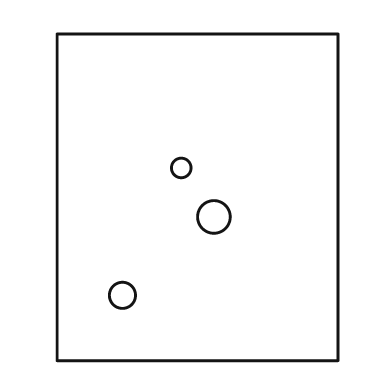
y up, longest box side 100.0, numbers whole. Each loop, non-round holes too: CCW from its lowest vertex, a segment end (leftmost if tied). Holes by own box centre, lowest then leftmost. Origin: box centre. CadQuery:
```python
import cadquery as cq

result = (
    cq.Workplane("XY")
    .moveTo(-43.0, -50.0)
    .lineTo(43.0, -50.0)
    .lineTo(43.0, 50.0)
    .lineTo(-43.0, 50.0)
    .close()
    .moveTo(-23.0, -30.0)
    .circle(4.0)
    .moveTo(5.0, -6.0)
    .circle(5.0)
    .moveTo(-5.0, 9.0)
    .circle(3.0)
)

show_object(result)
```